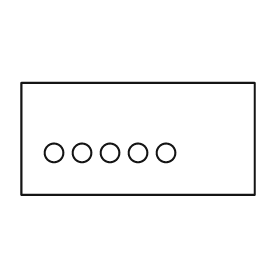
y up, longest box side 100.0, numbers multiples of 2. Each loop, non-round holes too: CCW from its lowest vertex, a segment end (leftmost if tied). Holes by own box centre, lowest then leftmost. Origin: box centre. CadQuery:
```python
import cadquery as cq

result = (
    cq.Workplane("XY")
    .moveTo(-50.0, -24.0)
    .lineTo(50.0, -24.0)
    .lineTo(50.0, 24.0)
    .lineTo(-50.0, 24.0)
    .close()
    .moveTo(-36.0, -6.0)
    .circle(4.0)
    .moveTo(-24.0, -6.0)
    .circle(4.0)
    .moveTo(-12.0, -6.0)
    .circle(4.0)
    .moveTo(0.0, -6.0)
    .circle(4.0)
    .moveTo(12.0, -6.0)
    .circle(4.0)
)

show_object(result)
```